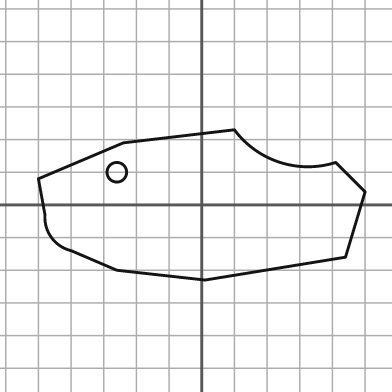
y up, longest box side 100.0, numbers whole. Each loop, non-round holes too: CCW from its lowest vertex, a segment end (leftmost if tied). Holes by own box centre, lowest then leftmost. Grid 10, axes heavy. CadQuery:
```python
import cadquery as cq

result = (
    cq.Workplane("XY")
    .moveTo(1.0, -23.0)
    .lineTo(44.0, -16.0)
    .lineTo(50.0, 4.0)
    .lineTo(41.0, 13.0)
    .threePointArc((24.0, 13.0), (10.0, 23.0))
    .lineTo(-24.0, 19.0)
    .lineTo(-50.0, 8.0)
    .lineTo(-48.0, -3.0)
    .threePointArc((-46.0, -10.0), (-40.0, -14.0))
    .lineTo(-26.0, -20.0)
    .close()
    .moveTo(-26.0, 10.0)
    .circle(3.0)
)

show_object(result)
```